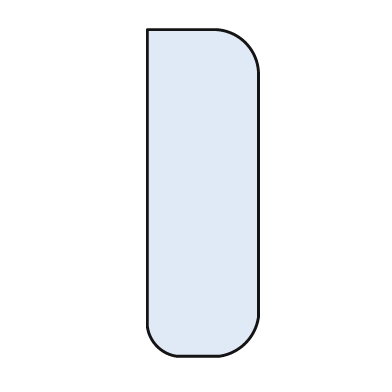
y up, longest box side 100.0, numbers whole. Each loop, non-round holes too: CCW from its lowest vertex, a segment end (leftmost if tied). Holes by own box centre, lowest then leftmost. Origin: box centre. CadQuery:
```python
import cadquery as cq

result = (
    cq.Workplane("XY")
    .moveTo(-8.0, -50.0)
    .lineTo(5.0, -50.0)
    .threePointArc((13.0, -46.0), (17.0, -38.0))
    .lineTo(17.0, 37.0)
    .threePointArc((13.0, 46.0), (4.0, 50.0))
    .lineTo(-17.0, 50.0)
    .lineTo(-17.0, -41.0)
    .threePointArc((-14.0, -47.0), (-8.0, -50.0))
    .close()
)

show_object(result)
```